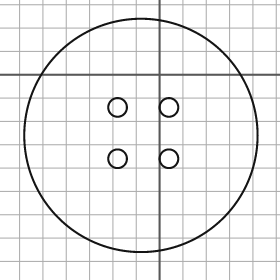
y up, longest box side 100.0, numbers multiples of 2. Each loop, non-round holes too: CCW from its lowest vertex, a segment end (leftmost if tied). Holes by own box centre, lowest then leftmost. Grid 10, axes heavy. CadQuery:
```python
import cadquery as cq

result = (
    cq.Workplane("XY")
    .moveTo(-8.0, -26.0)
    .circle(50.0)
    .moveTo(-18.0, -36.0)
    .circle(4.0)
    .moveTo(4.0, -36.0)
    .circle(4.0)
    .moveTo(-18.0, -14.0)
    .circle(4.0)
    .moveTo(4.0, -14.0)
    .circle(4.0)
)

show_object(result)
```